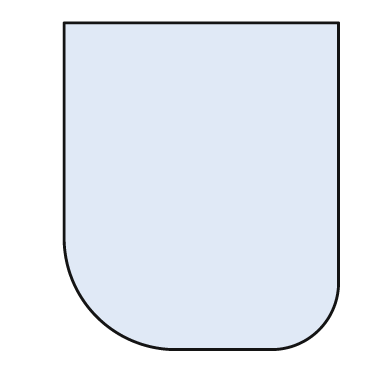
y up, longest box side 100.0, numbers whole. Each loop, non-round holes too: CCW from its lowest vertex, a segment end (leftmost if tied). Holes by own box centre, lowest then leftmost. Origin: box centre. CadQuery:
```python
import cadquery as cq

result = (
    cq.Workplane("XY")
    .moveTo(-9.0, -50.0)
    .lineTo(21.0, -50.0)
    .threePointArc((36.0, -44.0), (42.0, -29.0))
    .lineTo(42.0, 50.0)
    .lineTo(-42.0, 50.0)
    .lineTo(-42.0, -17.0)
    .threePointArc((-32.0, -40.0), (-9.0, -50.0))
    .close()
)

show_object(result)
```